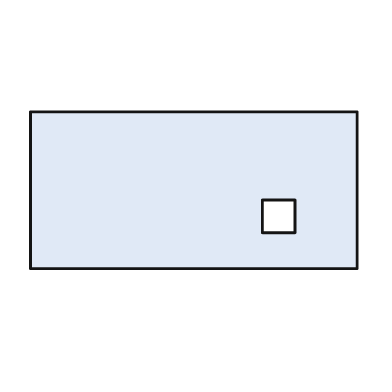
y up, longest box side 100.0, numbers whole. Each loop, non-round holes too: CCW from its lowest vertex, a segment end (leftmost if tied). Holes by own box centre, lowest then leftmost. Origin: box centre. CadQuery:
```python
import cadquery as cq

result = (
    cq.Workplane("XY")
    .moveTo(-50.0, -24.0)
    .lineTo(50.0, -24.0)
    .lineTo(50.0, 24.0)
    .lineTo(-50.0, 24.0)
    .close()
    .moveTo(21.0, -13.0)
    .lineTo(31.0, -13.0)
    .lineTo(31.0, -3.0)
    .lineTo(21.0, -3.0)
    .close()
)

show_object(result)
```